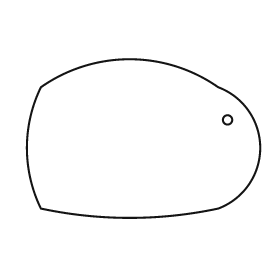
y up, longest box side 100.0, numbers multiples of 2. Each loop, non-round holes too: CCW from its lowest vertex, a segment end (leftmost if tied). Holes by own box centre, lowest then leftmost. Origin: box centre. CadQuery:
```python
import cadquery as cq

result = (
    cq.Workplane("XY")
    .moveTo(-44.0, -30.0)
    .threePointArc((-6.0, -34.0), (32.0, -30.0))
    .threePointArc((50.0, -4.0), (32.0, 22.0))
    .threePointArc((-6.0, 34.0), (-44.0, 22.0))
    .threePointArc((-50.0, -4.0), (-44.0, -30.0))
    .close()
    .moveTo(36.0, 8.0)
    .circle(2.0)
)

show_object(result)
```